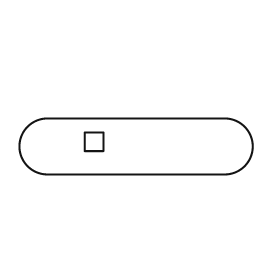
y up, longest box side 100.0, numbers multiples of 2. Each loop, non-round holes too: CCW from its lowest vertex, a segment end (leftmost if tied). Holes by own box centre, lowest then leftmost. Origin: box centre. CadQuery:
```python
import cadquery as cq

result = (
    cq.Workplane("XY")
    .moveTo(-38.0, -12.0)
    .lineTo(38.0, -12.0)
    .threePointArc((50.0, 0.0), (38.0, 12.0))
    .lineTo(-38.0, 12.0)
    .threePointArc((-50.0, 0.0), (-38.0, -12.0))
    .close()
    .moveTo(-22.0, -2.0)
    .lineTo(-14.0, -2.0)
    .lineTo(-14.0, 6.0)
    .lineTo(-22.0, 6.0)
    .close()
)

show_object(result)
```